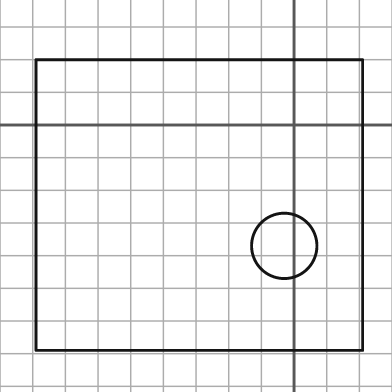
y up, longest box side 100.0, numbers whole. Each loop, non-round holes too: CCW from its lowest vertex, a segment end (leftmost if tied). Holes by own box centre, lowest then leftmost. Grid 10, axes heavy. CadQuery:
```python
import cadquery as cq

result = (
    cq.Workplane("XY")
    .moveTo(-79.0, -69.0)
    .lineTo(21.0, -69.0)
    .lineTo(21.0, 20.0)
    .lineTo(-79.0, 20.0)
    .close()
    .moveTo(-3.0, -37.0)
    .circle(10.0)
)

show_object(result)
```